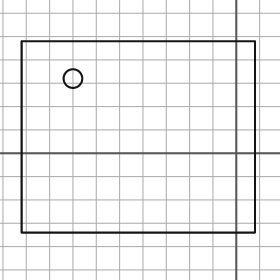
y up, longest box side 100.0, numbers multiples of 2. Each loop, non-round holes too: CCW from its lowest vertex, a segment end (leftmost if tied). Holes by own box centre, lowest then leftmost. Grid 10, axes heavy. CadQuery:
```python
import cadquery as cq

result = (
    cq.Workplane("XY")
    .moveTo(-92.0, -34.0)
    .lineTo(8.0, -34.0)
    .lineTo(8.0, 48.0)
    .lineTo(-92.0, 48.0)
    .close()
    .moveTo(-70.0, 32.0)
    .circle(4.0)
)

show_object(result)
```